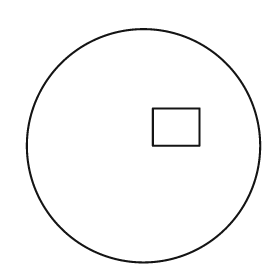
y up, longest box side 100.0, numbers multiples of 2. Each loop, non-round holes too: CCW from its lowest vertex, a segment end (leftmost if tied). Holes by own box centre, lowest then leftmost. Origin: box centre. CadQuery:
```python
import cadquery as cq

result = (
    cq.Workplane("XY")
    .moveTo(0.0, 0.0)
    .circle(50.0)
    .moveTo(4.0, 0.0)
    .lineTo(24.0, 0.0)
    .lineTo(24.0, 16.0)
    .lineTo(4.0, 16.0)
    .close()
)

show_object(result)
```